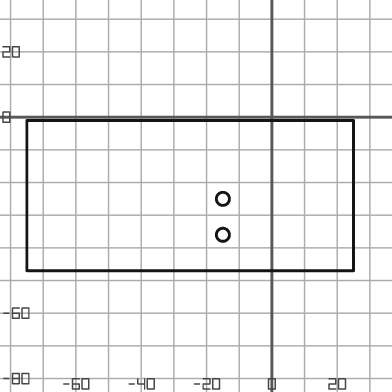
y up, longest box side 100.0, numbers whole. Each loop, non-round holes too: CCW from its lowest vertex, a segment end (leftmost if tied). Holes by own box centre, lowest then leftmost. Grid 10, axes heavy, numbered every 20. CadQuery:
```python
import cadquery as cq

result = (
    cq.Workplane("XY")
    .moveTo(-75.0, -47.0)
    .lineTo(25.0, -47.0)
    .lineTo(25.0, -1.0)
    .lineTo(-75.0, -1.0)
    .close()
    .moveTo(-15.0, -36.0)
    .circle(2.0)
    .moveTo(-15.0, -25.0)
    .circle(2.0)
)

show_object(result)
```